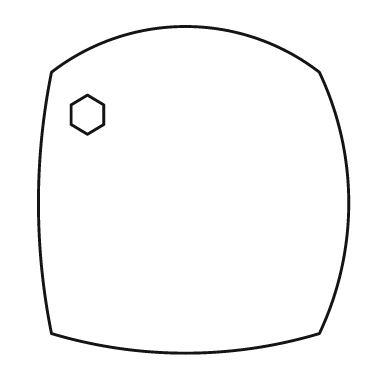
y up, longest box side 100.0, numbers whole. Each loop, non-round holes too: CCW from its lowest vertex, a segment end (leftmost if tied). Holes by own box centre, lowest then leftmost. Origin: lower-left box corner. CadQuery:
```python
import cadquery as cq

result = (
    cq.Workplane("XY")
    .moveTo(4.0, 6.0)
    .threePointArc((45.0, 0.0), (86.0, 6.0))
    .threePointArc((95.0, 46.0), (86.0, 86.0))
    .threePointArc((45.0, 100.0), (4.0, 86.0))
    .threePointArc((0.0, 46.0), (4.0, 6.0))
    .close()
    .moveTo(15.0, 67.0)
    .lineTo(20.0, 70.0)
    .lineTo(20.0, 76.0)
    .lineTo(15.0, 79.0)
    .lineTo(10.0, 76.0)
    .lineTo(10.0, 70.0)
    .close()
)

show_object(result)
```